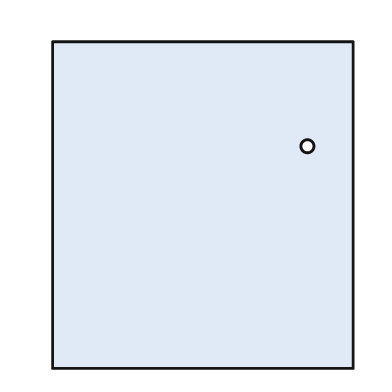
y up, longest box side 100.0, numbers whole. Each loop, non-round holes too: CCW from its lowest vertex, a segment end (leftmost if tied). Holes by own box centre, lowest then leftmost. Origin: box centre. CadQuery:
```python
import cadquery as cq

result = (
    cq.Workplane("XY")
    .moveTo(-46.0, -50.0)
    .lineTo(46.0, -50.0)
    .lineTo(46.0, 50.0)
    .lineTo(-46.0, 50.0)
    .close()
    .moveTo(32.0, 18.0)
    .circle(2.0)
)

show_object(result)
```